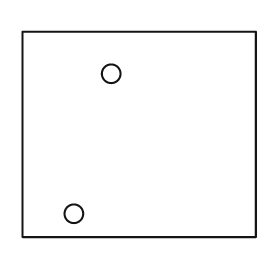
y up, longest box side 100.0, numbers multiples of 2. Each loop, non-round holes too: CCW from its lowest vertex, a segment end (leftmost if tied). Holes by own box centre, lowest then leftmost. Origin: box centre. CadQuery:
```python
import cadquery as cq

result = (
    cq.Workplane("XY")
    .moveTo(-50.0, -44.0)
    .lineTo(50.0, -44.0)
    .lineTo(50.0, 44.0)
    .lineTo(-50.0, 44.0)
    .close()
    .moveTo(-28.0, -34.0)
    .circle(4.0)
    .moveTo(-12.0, 26.0)
    .circle(4.0)
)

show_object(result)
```